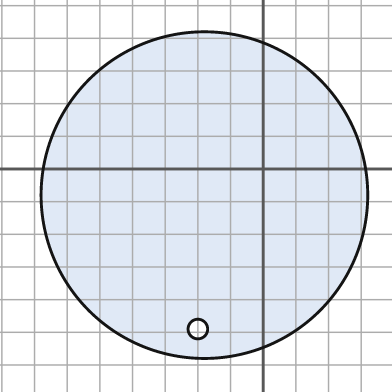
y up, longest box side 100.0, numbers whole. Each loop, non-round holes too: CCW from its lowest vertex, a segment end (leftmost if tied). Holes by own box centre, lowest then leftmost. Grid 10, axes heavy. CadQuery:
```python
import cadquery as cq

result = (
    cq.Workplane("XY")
    .moveTo(-18.0, -8.0)
    .circle(50.0)
    .moveTo(-20.0, -49.0)
    .circle(3.0)
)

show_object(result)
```